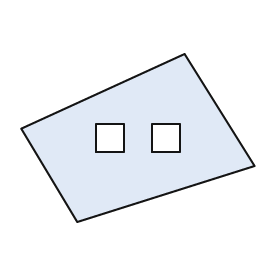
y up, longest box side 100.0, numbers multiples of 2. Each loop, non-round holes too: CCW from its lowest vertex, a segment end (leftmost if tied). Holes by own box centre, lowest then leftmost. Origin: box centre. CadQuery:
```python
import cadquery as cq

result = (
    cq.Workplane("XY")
    .moveTo(-26.0, -36.0)
    .lineTo(50.0, -12.0)
    .lineTo(20.0, 36.0)
    .lineTo(-50.0, 4.0)
    .close()
    .moveTo(-18.0, -6.0)
    .lineTo(-6.0, -6.0)
    .lineTo(-6.0, 6.0)
    .lineTo(-18.0, 6.0)
    .close()
    .moveTo(6.0, -6.0)
    .lineTo(18.0, -6.0)
    .lineTo(18.0, 6.0)
    .lineTo(6.0, 6.0)
    .close()
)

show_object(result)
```